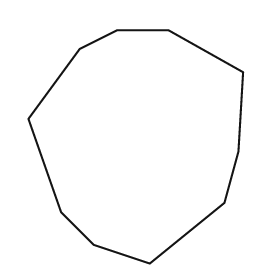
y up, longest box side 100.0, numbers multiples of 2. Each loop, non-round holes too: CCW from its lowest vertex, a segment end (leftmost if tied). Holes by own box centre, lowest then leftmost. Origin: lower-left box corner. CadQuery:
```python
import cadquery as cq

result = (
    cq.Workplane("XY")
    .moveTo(52.0, 0.0)
    .lineTo(84.0, 26.0)
    .lineTo(90.0, 48.0)
    .lineTo(92.0, 82.0)
    .lineTo(60.0, 100.0)
    .lineTo(38.0, 100.0)
    .lineTo(22.0, 92.0)
    .lineTo(0.0, 62.0)
    .lineTo(14.0, 22.0)
    .lineTo(28.0, 8.0)
    .close()
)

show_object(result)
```